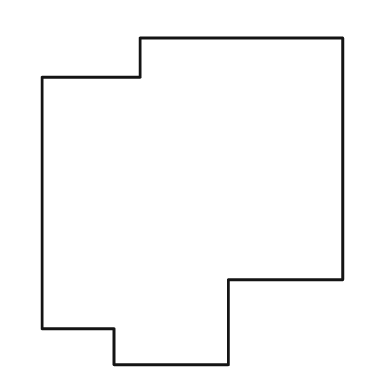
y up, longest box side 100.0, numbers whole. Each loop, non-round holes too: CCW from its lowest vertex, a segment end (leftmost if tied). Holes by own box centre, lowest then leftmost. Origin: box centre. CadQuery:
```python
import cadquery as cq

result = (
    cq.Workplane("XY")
    .moveTo(-24.0, -50.0)
    .lineTo(11.0, -50.0)
    .lineTo(11.0, -24.0)
    .lineTo(46.0, -24.0)
    .lineTo(46.0, 50.0)
    .lineTo(-16.0, 50.0)
    .lineTo(-16.0, 38.0)
    .lineTo(-46.0, 38.0)
    .lineTo(-46.0, -39.0)
    .lineTo(-24.0, -39.0)
    .close()
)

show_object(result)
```